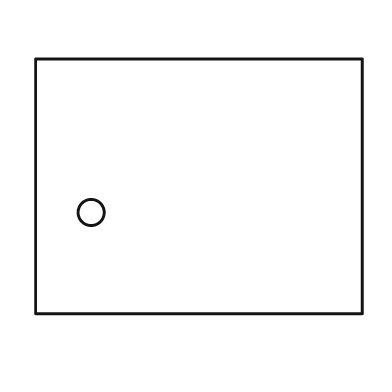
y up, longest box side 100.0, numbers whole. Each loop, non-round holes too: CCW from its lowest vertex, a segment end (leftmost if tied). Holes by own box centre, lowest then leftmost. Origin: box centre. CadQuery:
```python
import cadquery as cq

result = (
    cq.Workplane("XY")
    .moveTo(-50.0, -39.0)
    .lineTo(50.0, -39.0)
    .lineTo(50.0, 39.0)
    .lineTo(-50.0, 39.0)
    .close()
    .moveTo(-33.0, -8.0)
    .circle(4.0)
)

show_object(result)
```